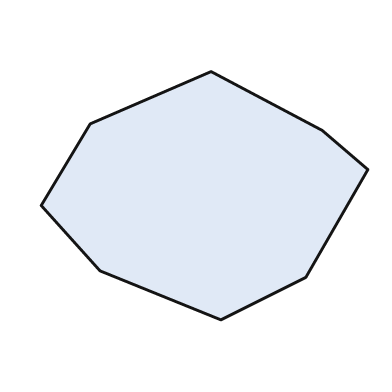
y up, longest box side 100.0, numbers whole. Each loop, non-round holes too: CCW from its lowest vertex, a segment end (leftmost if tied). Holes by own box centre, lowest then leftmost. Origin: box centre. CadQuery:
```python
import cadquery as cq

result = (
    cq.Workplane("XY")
    .moveTo(5.0, -38.0)
    .lineTo(31.0, -25.0)
    .lineTo(50.0, 8.0)
    .lineTo(36.0, 20.0)
    .lineTo(2.0, 38.0)
    .lineTo(-35.0, 22.0)
    .lineTo(-50.0, -3.0)
    .lineTo(-32.0, -23.0)
    .close()
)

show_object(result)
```